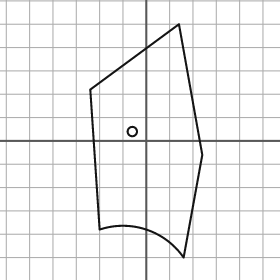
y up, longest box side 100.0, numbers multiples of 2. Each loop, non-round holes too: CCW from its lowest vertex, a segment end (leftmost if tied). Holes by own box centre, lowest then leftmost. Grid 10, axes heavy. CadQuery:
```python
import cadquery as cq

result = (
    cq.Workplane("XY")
    .moveTo(16.0, -50.0)
    .lineTo(24.0, -6.0)
    .lineTo(14.0, 50.0)
    .lineTo(-24.0, 22.0)
    .lineTo(-20.0, -38.0)
    .threePointArc((0.0, -38.0), (16.0, -50.0))
    .close()
    .moveTo(-6.0, 4.0)
    .circle(2.0)
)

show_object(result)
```